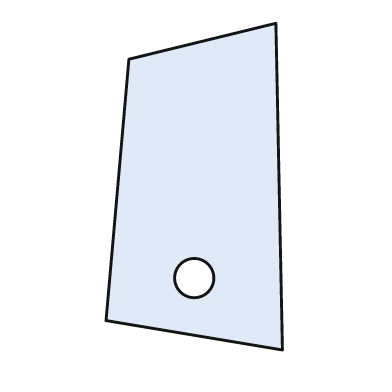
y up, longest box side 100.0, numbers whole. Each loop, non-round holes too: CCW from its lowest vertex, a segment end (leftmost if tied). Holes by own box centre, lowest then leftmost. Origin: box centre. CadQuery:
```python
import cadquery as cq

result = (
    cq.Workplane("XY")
    .moveTo(27.0, -50.0)
    .lineTo(25.0, 50.0)
    .lineTo(-20.0, 39.0)
    .lineTo(-27.0, -41.0)
    .close()
    .moveTo(0.0, -28.0)
    .circle(6.0)
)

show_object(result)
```